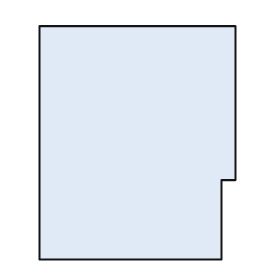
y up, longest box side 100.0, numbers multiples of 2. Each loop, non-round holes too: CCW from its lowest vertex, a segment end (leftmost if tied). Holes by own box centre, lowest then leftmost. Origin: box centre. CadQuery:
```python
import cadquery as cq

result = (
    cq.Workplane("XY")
    .moveTo(-42.0, -50.0)
    .lineTo(36.0, -50.0)
    .lineTo(36.0, -16.0)
    .lineTo(42.0, -16.0)
    .lineTo(42.0, 50.0)
    .lineTo(-42.0, 50.0)
    .close()
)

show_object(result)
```